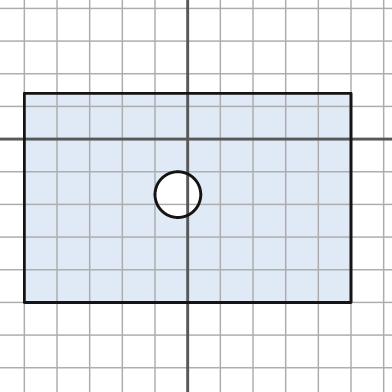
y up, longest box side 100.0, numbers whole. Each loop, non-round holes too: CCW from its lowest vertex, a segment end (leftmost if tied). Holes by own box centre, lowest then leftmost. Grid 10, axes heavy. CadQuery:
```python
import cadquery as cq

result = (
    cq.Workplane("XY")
    .moveTo(-50.0, -50.0)
    .lineTo(50.0, -50.0)
    .lineTo(50.0, 14.0)
    .lineTo(-50.0, 14.0)
    .close()
    .moveTo(-3.0, -17.0)
    .circle(7.0)
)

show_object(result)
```